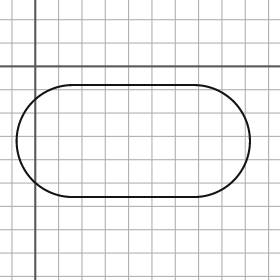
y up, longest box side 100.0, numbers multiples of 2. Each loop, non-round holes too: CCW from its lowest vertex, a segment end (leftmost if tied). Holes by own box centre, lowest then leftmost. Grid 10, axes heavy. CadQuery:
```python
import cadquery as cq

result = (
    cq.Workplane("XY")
    .moveTo(16.0, -56.0)
    .lineTo(68.0, -56.0)
    .threePointArc((92.0, -32.0), (68.0, -8.0))
    .lineTo(16.0, -8.0)
    .threePointArc((-8.0, -32.0), (16.0, -56.0))
    .close()
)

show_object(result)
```